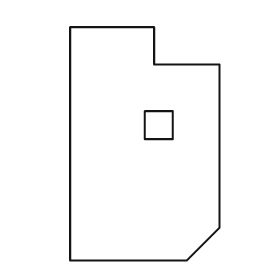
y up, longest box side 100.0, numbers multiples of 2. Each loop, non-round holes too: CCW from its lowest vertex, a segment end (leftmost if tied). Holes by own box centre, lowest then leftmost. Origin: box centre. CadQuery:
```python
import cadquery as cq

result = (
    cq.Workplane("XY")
    .moveTo(-32.0, -50.0)
    .lineTo(18.0, -50.0)
    .lineTo(32.0, -36.0)
    .lineTo(32.0, 34.0)
    .lineTo(4.0, 34.0)
    .lineTo(4.0, 50.0)
    .lineTo(-32.0, 50.0)
    .close()
    .moveTo(0.0, 2.0)
    .lineTo(12.0, 2.0)
    .lineTo(12.0, 14.0)
    .lineTo(0.0, 14.0)
    .close()
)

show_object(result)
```